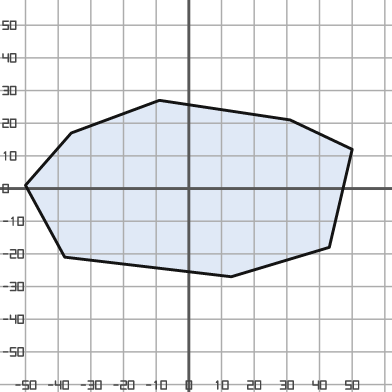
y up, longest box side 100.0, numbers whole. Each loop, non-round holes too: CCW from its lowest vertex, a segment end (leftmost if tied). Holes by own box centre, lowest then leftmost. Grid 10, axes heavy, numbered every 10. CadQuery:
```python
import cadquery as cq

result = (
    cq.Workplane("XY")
    .moveTo(13.0, -27.0)
    .lineTo(43.0, -18.0)
    .lineTo(50.0, 12.0)
    .lineTo(31.0, 21.0)
    .lineTo(-9.0, 27.0)
    .lineTo(-36.0, 17.0)
    .lineTo(-50.0, 1.0)
    .lineTo(-38.0, -21.0)
    .close()
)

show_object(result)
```